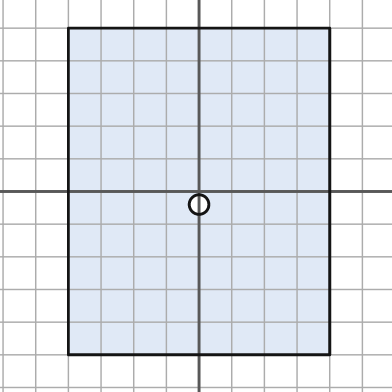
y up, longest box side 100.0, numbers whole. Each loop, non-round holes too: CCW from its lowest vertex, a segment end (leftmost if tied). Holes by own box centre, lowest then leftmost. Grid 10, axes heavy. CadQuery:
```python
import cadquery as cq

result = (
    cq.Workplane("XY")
    .moveTo(-40.0, -50.0)
    .lineTo(40.0, -50.0)
    .lineTo(40.0, 50.0)
    .lineTo(-40.0, 50.0)
    .close()
    .moveTo(0.0, -4.0)
    .circle(3.0)
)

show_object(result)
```